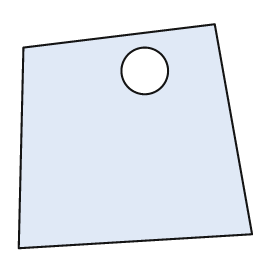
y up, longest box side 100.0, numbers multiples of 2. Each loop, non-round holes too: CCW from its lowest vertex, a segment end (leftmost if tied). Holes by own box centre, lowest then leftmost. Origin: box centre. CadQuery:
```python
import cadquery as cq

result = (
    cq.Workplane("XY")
    .moveTo(-50.0, -48.0)
    .lineTo(50.0, -42.0)
    .lineTo(34.0, 48.0)
    .lineTo(-48.0, 38.0)
    .close()
    .moveTo(4.0, 28.0)
    .circle(10.0)
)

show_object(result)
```